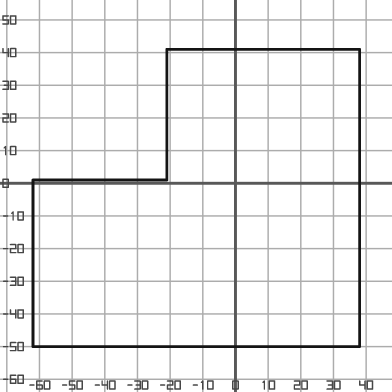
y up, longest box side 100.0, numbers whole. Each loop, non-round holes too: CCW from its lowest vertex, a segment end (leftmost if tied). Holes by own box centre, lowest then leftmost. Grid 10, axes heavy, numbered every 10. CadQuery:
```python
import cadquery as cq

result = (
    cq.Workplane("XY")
    .moveTo(-62.0, -50.0)
    .lineTo(38.0, -50.0)
    .lineTo(38.0, 41.0)
    .lineTo(-21.0, 41.0)
    .lineTo(-21.0, 1.0)
    .lineTo(-62.0, 1.0)
    .close()
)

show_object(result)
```